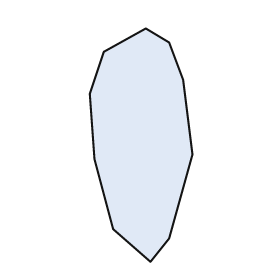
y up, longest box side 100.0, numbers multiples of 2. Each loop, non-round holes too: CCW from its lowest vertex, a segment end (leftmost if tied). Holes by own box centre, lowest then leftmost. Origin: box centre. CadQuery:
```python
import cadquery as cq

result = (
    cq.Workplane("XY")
    .moveTo(4.0, -50.0)
    .lineTo(12.0, -40.0)
    .lineTo(22.0, -4.0)
    .lineTo(18.0, 28.0)
    .lineTo(12.0, 44.0)
    .lineTo(2.0, 50.0)
    .lineTo(-16.0, 40.0)
    .lineTo(-22.0, 22.0)
    .lineTo(-20.0, -6.0)
    .lineTo(-12.0, -36.0)
    .close()
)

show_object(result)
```